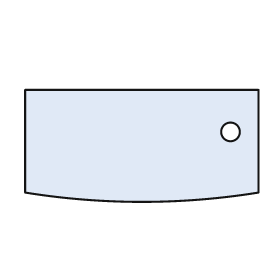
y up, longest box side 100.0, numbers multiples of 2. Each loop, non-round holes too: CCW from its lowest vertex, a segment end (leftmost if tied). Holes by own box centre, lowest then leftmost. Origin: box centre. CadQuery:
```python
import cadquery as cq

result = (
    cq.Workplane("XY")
    .moveTo(-50.0, -20.0)
    .threePointArc((0.0, -24.0), (50.0, -20.0))
    .lineTo(50.0, 24.0)
    .lineTo(-50.0, 24.0)
    .close()
    .moveTo(38.0, 6.0)
    .circle(4.0)
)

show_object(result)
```